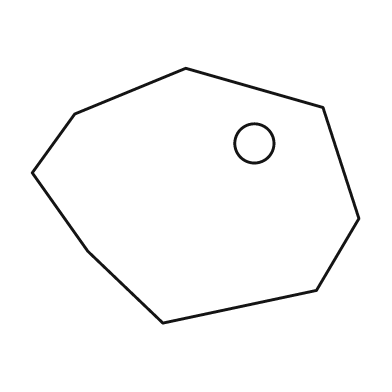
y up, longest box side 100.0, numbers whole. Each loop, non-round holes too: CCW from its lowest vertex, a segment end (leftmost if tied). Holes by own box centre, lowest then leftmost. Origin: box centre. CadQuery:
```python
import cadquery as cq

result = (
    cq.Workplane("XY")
    .moveTo(-10.0, -39.0)
    .lineTo(37.0, -29.0)
    .lineTo(50.0, -7.0)
    .lineTo(39.0, 27.0)
    .lineTo(-3.0, 39.0)
    .lineTo(-37.0, 25.0)
    .lineTo(-50.0, 7.0)
    .lineTo(-33.0, -17.0)
    .close()
    .moveTo(18.0, 16.0)
    .circle(6.0)
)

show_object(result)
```